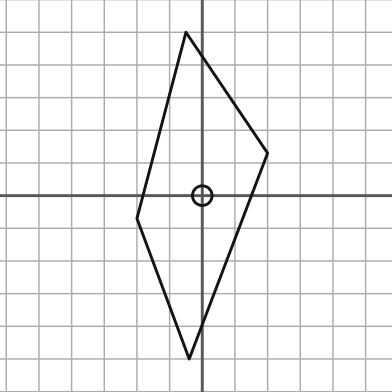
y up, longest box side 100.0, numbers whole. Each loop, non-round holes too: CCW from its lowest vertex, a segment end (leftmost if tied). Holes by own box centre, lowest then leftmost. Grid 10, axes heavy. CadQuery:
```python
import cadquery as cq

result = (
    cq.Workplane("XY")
    .moveTo(-4.0, -50.0)
    .lineTo(20.0, 13.0)
    .lineTo(-5.0, 50.0)
    .lineTo(-20.0, -7.0)
    .close()
    .moveTo(0.0, 0.0)
    .circle(3.0)
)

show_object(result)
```